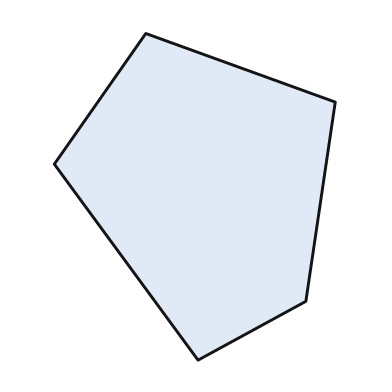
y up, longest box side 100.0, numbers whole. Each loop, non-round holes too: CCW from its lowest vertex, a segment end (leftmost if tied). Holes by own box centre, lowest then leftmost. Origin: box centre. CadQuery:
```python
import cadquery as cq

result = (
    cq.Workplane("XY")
    .moveTo(1.0, -50.0)
    .lineTo(34.0, -32.0)
    .lineTo(43.0, 29.0)
    .lineTo(-15.0, 50.0)
    .lineTo(-43.0, 10.0)
    .close()
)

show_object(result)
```